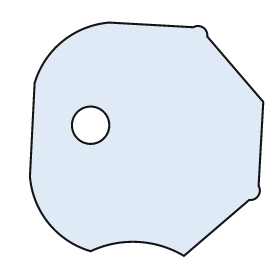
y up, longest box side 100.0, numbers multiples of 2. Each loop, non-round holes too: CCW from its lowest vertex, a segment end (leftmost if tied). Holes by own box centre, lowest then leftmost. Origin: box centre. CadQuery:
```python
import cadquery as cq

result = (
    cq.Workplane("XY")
    .moveTo(16.0, -50.0)
    .lineTo(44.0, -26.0)
    .threePointArc((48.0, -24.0), (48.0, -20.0))
    .lineTo(50.0, 16.0)
    .lineTo(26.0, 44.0)
    .threePointArc((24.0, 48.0), (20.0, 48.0))
    .lineTo(-16.0, 50.0)
    .threePointArc((-36.0, 42.0), (-48.0, 24.0))
    .lineTo(-50.0, -16.0)
    .threePointArc((-42.0, -36.0), (-24.0, -48.0))
    .threePointArc((-4.0, -44.0), (16.0, -50.0))
    .close()
    .moveTo(-24.0, 6.0)
    .circle(8.0)
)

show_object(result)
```